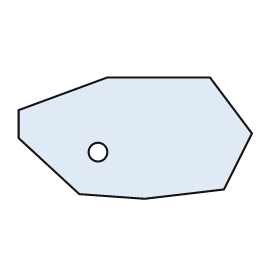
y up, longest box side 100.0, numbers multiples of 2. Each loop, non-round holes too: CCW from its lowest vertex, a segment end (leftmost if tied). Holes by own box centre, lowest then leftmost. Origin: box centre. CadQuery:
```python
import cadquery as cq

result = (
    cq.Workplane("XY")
    .moveTo(4.0, -26.0)
    .lineTo(38.0, -22.0)
    .lineTo(50.0, 2.0)
    .lineTo(32.0, 26.0)
    .lineTo(-12.0, 26.0)
    .lineTo(-50.0, 12.0)
    .lineTo(-50.0, 0.0)
    .lineTo(-24.0, -24.0)
    .close()
    .moveTo(-16.0, -6.0)
    .circle(4.0)
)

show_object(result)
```